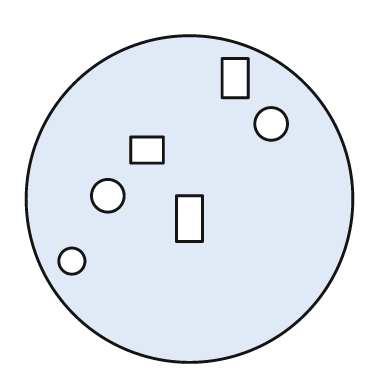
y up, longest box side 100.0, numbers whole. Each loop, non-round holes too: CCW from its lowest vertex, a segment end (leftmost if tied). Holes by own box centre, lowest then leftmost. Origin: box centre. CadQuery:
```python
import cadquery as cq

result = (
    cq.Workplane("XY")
    .moveTo(0.0, 0.0)
    .circle(50.0)
    .moveTo(-36.0, -19.0)
    .circle(4.0)
    .moveTo(-4.0, -13.0)
    .lineTo(4.0, -13.0)
    .lineTo(4.0, 1.0)
    .lineTo(-4.0, 1.0)
    .close()
    .moveTo(-25.0, 1.0)
    .circle(5.0)
    .moveTo(-18.0, 11.0)
    .lineTo(-8.0, 11.0)
    .lineTo(-8.0, 19.0)
    .lineTo(-18.0, 19.0)
    .close()
    .moveTo(25.0, 23.0)
    .circle(5.0)
    .moveTo(10.0, 31.0)
    .lineTo(18.0, 31.0)
    .lineTo(18.0, 43.0)
    .lineTo(10.0, 43.0)
    .close()
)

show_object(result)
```